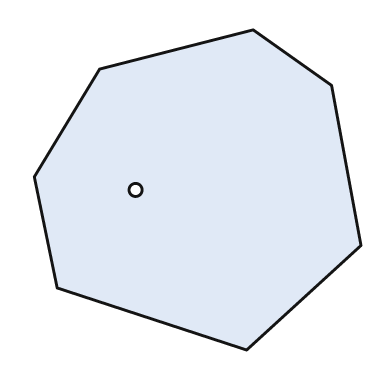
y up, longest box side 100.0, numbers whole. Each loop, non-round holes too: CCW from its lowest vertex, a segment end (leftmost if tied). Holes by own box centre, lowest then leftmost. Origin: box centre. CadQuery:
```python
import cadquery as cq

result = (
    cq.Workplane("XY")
    .moveTo(15.0, -49.0)
    .lineTo(50.0, -17.0)
    .lineTo(41.0, 32.0)
    .lineTo(17.0, 49.0)
    .lineTo(-30.0, 37.0)
    .lineTo(-50.0, 4.0)
    .lineTo(-43.0, -30.0)
    .close()
    .moveTo(-19.0, 0.0)
    .circle(2.0)
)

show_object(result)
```